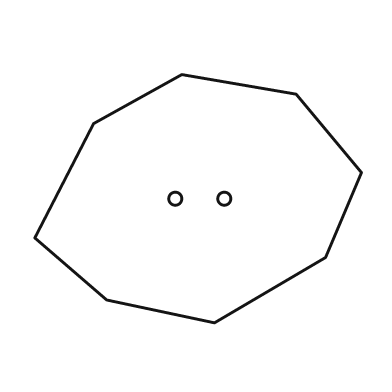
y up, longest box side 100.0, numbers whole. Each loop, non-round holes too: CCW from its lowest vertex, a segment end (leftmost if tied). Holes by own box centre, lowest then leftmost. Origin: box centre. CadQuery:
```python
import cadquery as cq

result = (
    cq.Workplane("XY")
    .moveTo(5.0, -38.0)
    .lineTo(39.0, -18.0)
    .lineTo(50.0, 8.0)
    .lineTo(30.0, 32.0)
    .lineTo(-5.0, 38.0)
    .lineTo(-32.0, 23.0)
    .lineTo(-50.0, -12.0)
    .lineTo(-28.0, -31.0)
    .close()
    .moveTo(-7.0, 0.0)
    .circle(2.0)
    .moveTo(8.0, 0.0)
    .circle(2.0)
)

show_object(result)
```